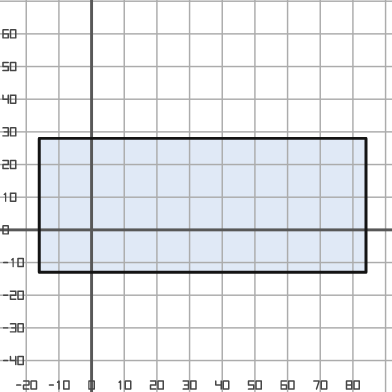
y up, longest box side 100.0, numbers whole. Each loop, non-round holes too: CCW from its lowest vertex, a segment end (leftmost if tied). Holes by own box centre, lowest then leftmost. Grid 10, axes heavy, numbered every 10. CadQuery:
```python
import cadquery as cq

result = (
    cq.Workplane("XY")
    .moveTo(-16.0, -13.0)
    .lineTo(84.0, -13.0)
    .lineTo(84.0, 28.0)
    .lineTo(-16.0, 28.0)
    .close()
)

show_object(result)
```